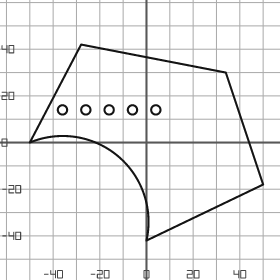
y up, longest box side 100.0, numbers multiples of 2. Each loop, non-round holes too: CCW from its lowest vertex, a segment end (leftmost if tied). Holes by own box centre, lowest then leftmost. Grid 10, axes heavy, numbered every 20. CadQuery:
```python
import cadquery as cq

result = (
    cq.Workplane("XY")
    .moveTo(0.0, -42.0)
    .lineTo(50.0, -18.0)
    .lineTo(34.0, 30.0)
    .lineTo(-28.0, 42.0)
    .lineTo(-50.0, 0.0)
    .threePointArc((-12.0, -6.0), (0.0, -42.0))
    .close()
    .moveTo(-36.0, 14.0)
    .circle(2.0)
    .moveTo(-26.0, 14.0)
    .circle(2.0)
    .moveTo(-16.0, 14.0)
    .circle(2.0)
    .moveTo(-6.0, 14.0)
    .circle(2.0)
    .moveTo(4.0, 14.0)
    .circle(2.0)
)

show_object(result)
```